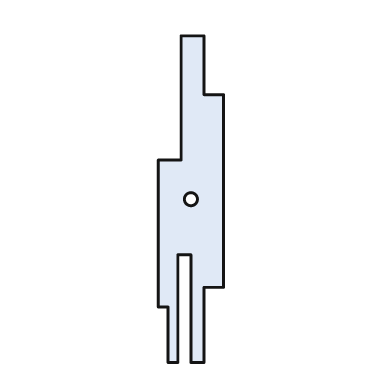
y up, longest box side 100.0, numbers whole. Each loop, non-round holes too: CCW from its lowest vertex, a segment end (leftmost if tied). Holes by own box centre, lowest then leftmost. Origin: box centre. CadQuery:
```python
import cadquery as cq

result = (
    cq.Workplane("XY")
    .moveTo(-7.0, -50.0)
    .lineTo(-4.0, -50.0)
    .lineTo(-4.0, -17.0)
    .lineTo(0.0, -17.0)
    .lineTo(0.0, -50.0)
    .lineTo(4.0, -50.0)
    .lineTo(4.0, -27.0)
    .lineTo(10.0, -27.0)
    .lineTo(10.0, 32.0)
    .lineTo(4.0, 32.0)
    .lineTo(4.0, 50.0)
    .lineTo(-3.0, 50.0)
    .lineTo(-3.0, 12.0)
    .lineTo(-10.0, 12.0)
    .lineTo(-10.0, -33.0)
    .lineTo(-7.0, -33.0)
    .close()
    .moveTo(0.0, 0.0)
    .circle(2.0)
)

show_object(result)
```